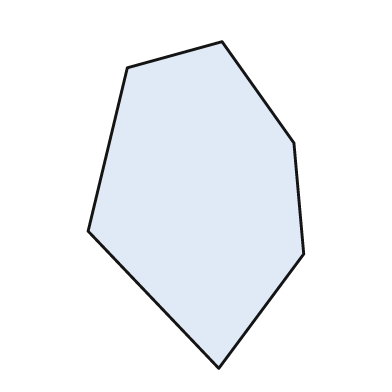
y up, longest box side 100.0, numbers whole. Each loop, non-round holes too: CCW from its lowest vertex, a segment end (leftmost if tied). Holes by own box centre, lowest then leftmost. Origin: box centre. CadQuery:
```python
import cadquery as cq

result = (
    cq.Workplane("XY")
    .moveTo(7.0, -50.0)
    .lineTo(33.0, -15.0)
    .lineTo(30.0, 19.0)
    .lineTo(8.0, 50.0)
    .lineTo(-21.0, 42.0)
    .lineTo(-33.0, -8.0)
    .close()
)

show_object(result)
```